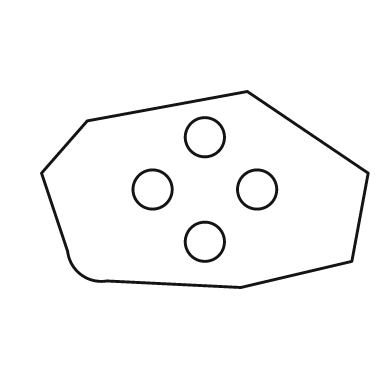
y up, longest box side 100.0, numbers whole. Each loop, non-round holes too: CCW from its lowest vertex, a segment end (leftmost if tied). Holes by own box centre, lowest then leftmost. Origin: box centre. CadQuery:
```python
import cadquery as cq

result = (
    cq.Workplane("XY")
    .moveTo(11.0, -30.0)
    .lineTo(45.0, -22.0)
    .lineTo(50.0, 5.0)
    .lineTo(13.0, 30.0)
    .lineTo(-36.0, 21.0)
    .lineTo(-50.0, 5.0)
    .lineTo(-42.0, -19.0)
    .threePointArc((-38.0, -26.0), (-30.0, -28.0))
    .close()
    .moveTo(0.0, -16.0)
    .circle(6.0)
    .moveTo(-16.0, 0.0)
    .circle(6.0)
    .moveTo(16.0, 0.0)
    .circle(6.0)
    .moveTo(0.0, 16.0)
    .circle(6.0)
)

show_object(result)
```